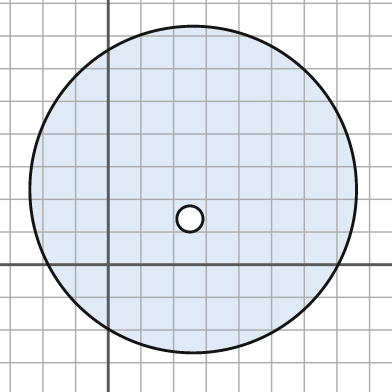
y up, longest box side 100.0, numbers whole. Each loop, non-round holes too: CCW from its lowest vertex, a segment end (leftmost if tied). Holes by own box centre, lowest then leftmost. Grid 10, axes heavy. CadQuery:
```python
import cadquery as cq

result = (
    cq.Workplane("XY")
    .moveTo(26.0, 23.0)
    .circle(50.0)
    .moveTo(25.0, 14.0)
    .circle(4.0)
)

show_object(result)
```